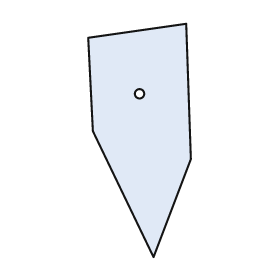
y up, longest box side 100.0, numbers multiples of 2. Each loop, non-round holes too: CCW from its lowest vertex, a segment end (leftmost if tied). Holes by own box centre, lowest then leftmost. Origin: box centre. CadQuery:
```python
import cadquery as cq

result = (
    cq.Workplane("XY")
    .moveTo(6.0, -50.0)
    .lineTo(22.0, -8.0)
    .lineTo(20.0, 50.0)
    .lineTo(-22.0, 44.0)
    .lineTo(-20.0, 4.0)
    .close()
    .moveTo(0.0, 20.0)
    .circle(2.0)
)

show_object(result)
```